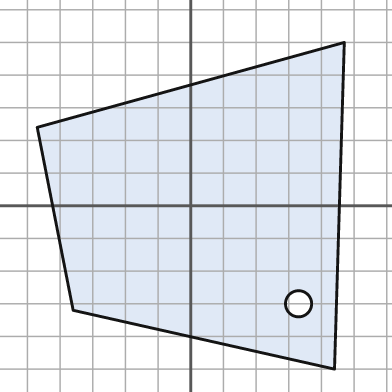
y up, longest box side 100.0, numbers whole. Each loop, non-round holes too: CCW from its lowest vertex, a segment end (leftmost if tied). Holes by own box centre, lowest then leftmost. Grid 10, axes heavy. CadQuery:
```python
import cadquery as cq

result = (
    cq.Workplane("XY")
    .moveTo(44.0, -50.0)
    .lineTo(47.0, 50.0)
    .lineTo(-47.0, 24.0)
    .lineTo(-36.0, -32.0)
    .close()
    .moveTo(33.0, -30.0)
    .circle(4.0)
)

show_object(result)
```